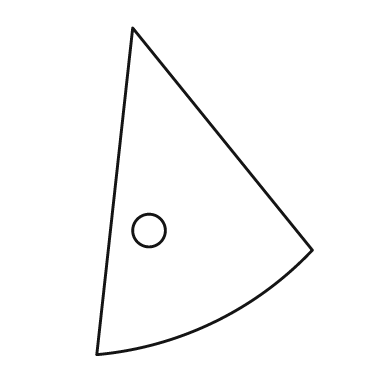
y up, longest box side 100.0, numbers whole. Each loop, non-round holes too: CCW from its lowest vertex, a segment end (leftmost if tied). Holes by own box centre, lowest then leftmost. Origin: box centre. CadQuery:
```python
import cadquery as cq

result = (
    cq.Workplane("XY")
    .moveTo(-33.0, -50.0)
    .threePointArc((3.0, -40.0), (33.0, -18.0))
    .lineTo(-22.0, 50.0)
    .close()
    .moveTo(-17.0, -12.0)
    .circle(5.0)
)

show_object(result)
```